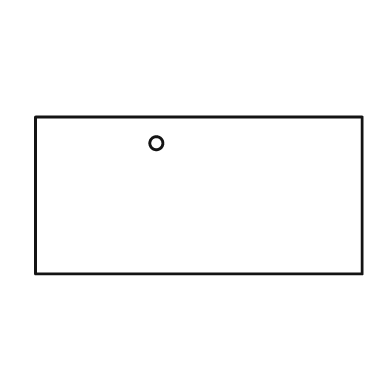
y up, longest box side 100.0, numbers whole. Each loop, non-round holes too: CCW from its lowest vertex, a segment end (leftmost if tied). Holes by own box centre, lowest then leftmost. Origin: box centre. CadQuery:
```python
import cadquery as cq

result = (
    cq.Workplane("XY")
    .moveTo(-50.0, -24.0)
    .lineTo(50.0, -24.0)
    .lineTo(50.0, 24.0)
    .lineTo(-50.0, 24.0)
    .close()
    .moveTo(-13.0, 16.0)
    .circle(2.0)
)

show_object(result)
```